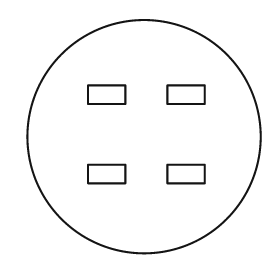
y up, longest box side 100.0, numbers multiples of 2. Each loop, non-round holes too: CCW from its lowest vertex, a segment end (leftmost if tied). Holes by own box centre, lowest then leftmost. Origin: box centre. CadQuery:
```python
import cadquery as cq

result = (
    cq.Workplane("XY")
    .moveTo(0.0, 0.0)
    .circle(50.0)
    .moveTo(-24.0, -20.0)
    .lineTo(-8.0, -20.0)
    .lineTo(-8.0, -12.0)
    .lineTo(-24.0, -12.0)
    .close()
    .moveTo(10.0, -20.0)
    .lineTo(26.0, -20.0)
    .lineTo(26.0, -12.0)
    .lineTo(10.0, -12.0)
    .close()
    .moveTo(-24.0, 14.0)
    .lineTo(-8.0, 14.0)
    .lineTo(-8.0, 22.0)
    .lineTo(-24.0, 22.0)
    .close()
    .moveTo(10.0, 14.0)
    .lineTo(26.0, 14.0)
    .lineTo(26.0, 22.0)
    .lineTo(10.0, 22.0)
    .close()
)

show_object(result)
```